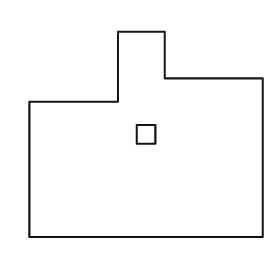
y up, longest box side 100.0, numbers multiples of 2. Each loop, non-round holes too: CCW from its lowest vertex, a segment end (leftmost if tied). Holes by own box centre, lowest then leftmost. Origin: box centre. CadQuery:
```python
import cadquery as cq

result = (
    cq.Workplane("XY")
    .moveTo(-50.0, -44.0)
    .lineTo(50.0, -44.0)
    .lineTo(50.0, 24.0)
    .lineTo(8.0, 24.0)
    .lineTo(8.0, 44.0)
    .lineTo(-12.0, 44.0)
    .lineTo(-12.0, 14.0)
    .lineTo(-50.0, 14.0)
    .close()
    .moveTo(-4.0, -4.0)
    .lineTo(4.0, -4.0)
    .lineTo(4.0, 4.0)
    .lineTo(-4.0, 4.0)
    .close()
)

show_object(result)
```